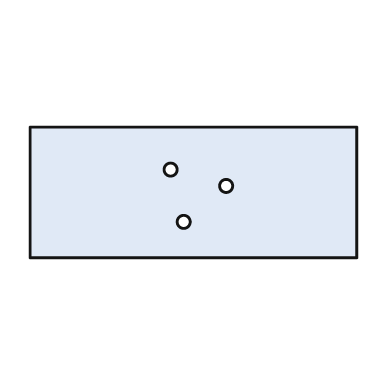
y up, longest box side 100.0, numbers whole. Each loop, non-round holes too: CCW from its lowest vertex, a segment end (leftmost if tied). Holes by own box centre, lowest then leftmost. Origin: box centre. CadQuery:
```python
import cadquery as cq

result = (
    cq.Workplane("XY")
    .moveTo(-50.0, -20.0)
    .lineTo(50.0, -20.0)
    .lineTo(50.0, 20.0)
    .lineTo(-50.0, 20.0)
    .close()
    .moveTo(-3.0, -9.0)
    .circle(2.0)
    .moveTo(10.0, 2.0)
    .circle(2.0)
    .moveTo(-7.0, 7.0)
    .circle(2.0)
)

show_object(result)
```